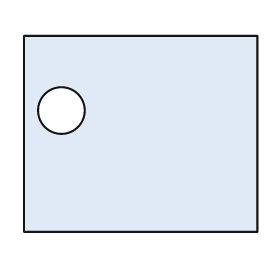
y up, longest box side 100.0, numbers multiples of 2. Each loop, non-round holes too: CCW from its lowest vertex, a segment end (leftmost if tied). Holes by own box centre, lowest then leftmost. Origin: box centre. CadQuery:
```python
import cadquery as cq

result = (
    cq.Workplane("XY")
    .moveTo(-50.0, -42.0)
    .lineTo(50.0, -42.0)
    .lineTo(50.0, 42.0)
    .lineTo(-50.0, 42.0)
    .close()
    .moveTo(-34.0, 10.0)
    .circle(10.0)
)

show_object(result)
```